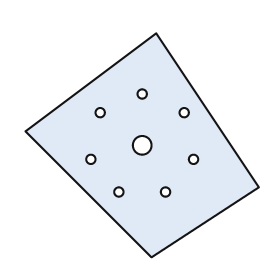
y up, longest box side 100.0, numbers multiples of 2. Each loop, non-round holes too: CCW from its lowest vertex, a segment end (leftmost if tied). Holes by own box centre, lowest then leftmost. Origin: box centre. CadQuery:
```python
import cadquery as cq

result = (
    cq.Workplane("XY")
    .moveTo(4.0, -48.0)
    .lineTo(50.0, -18.0)
    .lineTo(6.0, 48.0)
    .lineTo(-50.0, 6.0)
    .close()
    .moveTo(-10.0, -20.0)
    .circle(2.0)
    .moveTo(10.0, -20.0)
    .circle(2.0)
    .moveTo(-22.0, -6.0)
    .circle(2.0)
    .moveTo(22.0, -6.0)
    .circle(2.0)
    .moveTo(0.0, 0.0)
    .circle(4.0)
    .moveTo(-18.0, 14.0)
    .circle(2.0)
    .moveTo(18.0, 14.0)
    .circle(2.0)
    .moveTo(0.0, 22.0)
    .circle(2.0)
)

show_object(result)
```